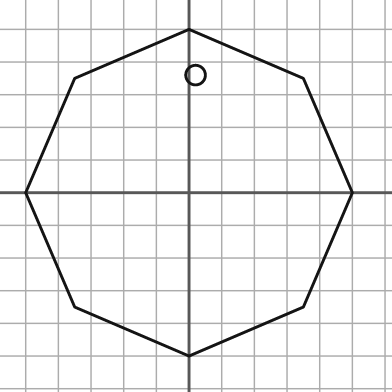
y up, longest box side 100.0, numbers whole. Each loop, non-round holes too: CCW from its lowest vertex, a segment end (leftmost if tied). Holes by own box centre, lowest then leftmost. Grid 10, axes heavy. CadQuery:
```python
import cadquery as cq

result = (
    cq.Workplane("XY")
    .moveTo(0.0, -50.0)
    .lineTo(35.0, -35.0)
    .lineTo(50.0, 0.0)
    .lineTo(35.0, 35.0)
    .lineTo(0.0, 50.0)
    .lineTo(-35.0, 35.0)
    .lineTo(-50.0, 0.0)
    .lineTo(-35.0, -35.0)
    .close()
    .moveTo(2.0, 36.0)
    .circle(3.0)
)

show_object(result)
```